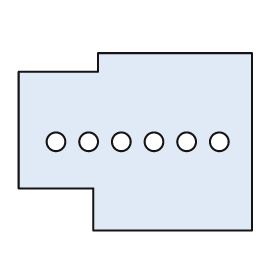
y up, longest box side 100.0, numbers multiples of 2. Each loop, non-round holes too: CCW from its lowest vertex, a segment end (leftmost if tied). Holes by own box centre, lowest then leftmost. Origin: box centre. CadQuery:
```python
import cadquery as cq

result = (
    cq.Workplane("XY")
    .moveTo(-18.0, -38.0)
    .lineTo(50.0, -38.0)
    .lineTo(50.0, 38.0)
    .lineTo(-16.0, 38.0)
    .lineTo(-16.0, 30.0)
    .lineTo(-50.0, 30.0)
    .lineTo(-50.0, -20.0)
    .lineTo(-18.0, -20.0)
    .close()
    .moveTo(-34.0, 0.0)
    .circle(4.0)
    .moveTo(-20.0, 0.0)
    .circle(4.0)
    .moveTo(-6.0, 0.0)
    .circle(4.0)
    .moveTo(8.0, 0.0)
    .circle(4.0)
    .moveTo(22.0, 0.0)
    .circle(4.0)
    .moveTo(36.0, 0.0)
    .circle(4.0)
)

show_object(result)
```